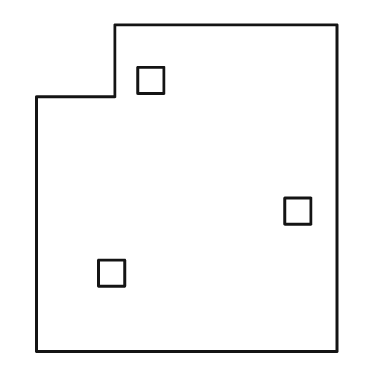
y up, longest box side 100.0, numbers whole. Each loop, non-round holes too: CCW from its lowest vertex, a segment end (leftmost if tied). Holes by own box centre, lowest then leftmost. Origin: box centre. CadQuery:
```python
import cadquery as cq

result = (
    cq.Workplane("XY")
    .moveTo(-46.0, -50.0)
    .lineTo(46.0, -50.0)
    .lineTo(46.0, 50.0)
    .lineTo(-22.0, 50.0)
    .lineTo(-22.0, 28.0)
    .lineTo(-46.0, 28.0)
    .close()
    .moveTo(-27.0, -30.0)
    .lineTo(-19.0, -30.0)
    .lineTo(-19.0, -22.0)
    .lineTo(-27.0, -22.0)
    .close()
    .moveTo(30.0, -11.0)
    .lineTo(38.0, -11.0)
    .lineTo(38.0, -3.0)
    .lineTo(30.0, -3.0)
    .close()
    .moveTo(-15.0, 29.0)
    .lineTo(-7.0, 29.0)
    .lineTo(-7.0, 37.0)
    .lineTo(-15.0, 37.0)
    .close()
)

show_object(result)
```